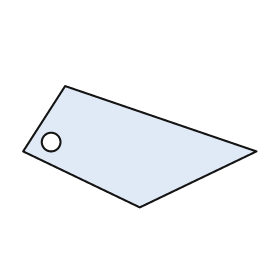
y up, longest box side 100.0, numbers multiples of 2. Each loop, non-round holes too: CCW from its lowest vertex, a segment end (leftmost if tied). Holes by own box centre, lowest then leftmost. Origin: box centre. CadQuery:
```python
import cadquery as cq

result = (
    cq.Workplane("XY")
    .moveTo(0.0, -26.0)
    .lineTo(50.0, -2.0)
    .lineTo(-32.0, 26.0)
    .lineTo(-50.0, -2.0)
    .close()
    .moveTo(-38.0, 2.0)
    .circle(4.0)
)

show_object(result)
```